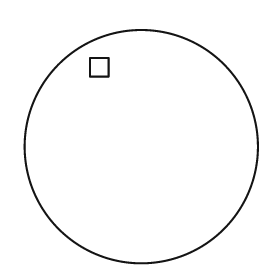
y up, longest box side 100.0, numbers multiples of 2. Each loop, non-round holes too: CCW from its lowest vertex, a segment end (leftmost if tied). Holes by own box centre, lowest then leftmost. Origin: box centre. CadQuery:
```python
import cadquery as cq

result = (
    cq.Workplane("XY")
    .moveTo(0.0, 0.0)
    .circle(50.0)
    .moveTo(-22.0, 30.0)
    .lineTo(-14.0, 30.0)
    .lineTo(-14.0, 38.0)
    .lineTo(-22.0, 38.0)
    .close()
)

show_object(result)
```